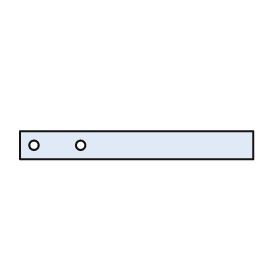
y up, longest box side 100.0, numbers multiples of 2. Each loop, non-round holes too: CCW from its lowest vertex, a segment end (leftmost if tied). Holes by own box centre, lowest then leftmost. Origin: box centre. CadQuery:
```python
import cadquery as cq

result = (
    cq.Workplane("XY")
    .moveTo(-50.0, -6.0)
    .lineTo(50.0, -6.0)
    .lineTo(50.0, 6.0)
    .lineTo(-50.0, 6.0)
    .close()
    .moveTo(-44.0, 0.0)
    .circle(2.0)
    .moveTo(-24.0, 0.0)
    .circle(2.0)
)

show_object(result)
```